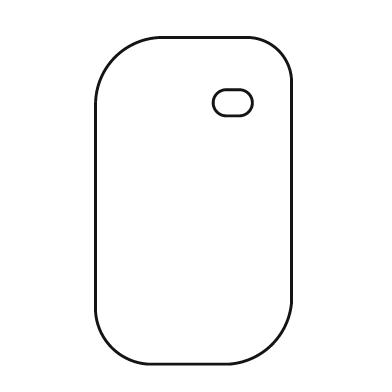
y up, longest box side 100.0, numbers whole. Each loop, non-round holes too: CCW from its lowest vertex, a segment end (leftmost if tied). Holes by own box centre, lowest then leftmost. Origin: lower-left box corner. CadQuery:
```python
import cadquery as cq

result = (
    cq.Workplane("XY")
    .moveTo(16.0, 0.0)
    .lineTo(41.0, 0.0)
    .threePointArc((54.0, 6.0), (60.0, 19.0))
    .lineTo(60.0, 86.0)
    .threePointArc((56.0, 96.0), (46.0, 100.0))
    .lineTo(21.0, 100.0)
    .threePointArc((6.0, 94.0), (0.0, 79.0))
    .lineTo(0.0, 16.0)
    .threePointArc((5.0, 5.0), (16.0, 0.0))
    .close()
    .moveTo(40.0, 76.0)
    .lineTo(44.0, 76.0)
    .threePointArc((48.0, 80.0), (44.0, 84.0))
    .lineTo(40.0, 84.0)
    .threePointArc((36.0, 80.0), (40.0, 76.0))
    .close()
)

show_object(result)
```